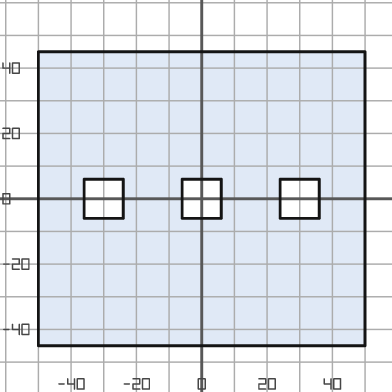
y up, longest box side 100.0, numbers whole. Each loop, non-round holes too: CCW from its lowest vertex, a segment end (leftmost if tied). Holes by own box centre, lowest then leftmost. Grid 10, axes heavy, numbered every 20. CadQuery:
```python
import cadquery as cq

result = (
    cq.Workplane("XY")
    .moveTo(-50.0, -45.0)
    .lineTo(50.0, -45.0)
    .lineTo(50.0, 45.0)
    .lineTo(-50.0, 45.0)
    .close()
    .moveTo(-36.0, -6.0)
    .lineTo(-24.0, -6.0)
    .lineTo(-24.0, 6.0)
    .lineTo(-36.0, 6.0)
    .close()
    .moveTo(-6.0, -6.0)
    .lineTo(6.0, -6.0)
    .lineTo(6.0, 6.0)
    .lineTo(-6.0, 6.0)
    .close()
    .moveTo(24.0, -6.0)
    .lineTo(36.0, -6.0)
    .lineTo(36.0, 6.0)
    .lineTo(24.0, 6.0)
    .close()
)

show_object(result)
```